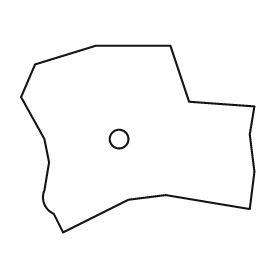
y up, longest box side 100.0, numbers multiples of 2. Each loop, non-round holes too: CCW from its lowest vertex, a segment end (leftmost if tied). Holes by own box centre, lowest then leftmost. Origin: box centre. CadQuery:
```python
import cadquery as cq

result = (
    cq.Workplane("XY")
    .moveTo(-32.0, -40.0)
    .lineTo(-4.0, -26.0)
    .lineTo(12.0, -24.0)
    .lineTo(48.0, -30.0)
    .lineTo(50.0, -14.0)
    .lineTo(48.0, 2.0)
    .lineTo(50.0, 14.0)
    .lineTo(22.0, 16.0)
    .lineTo(14.0, 40.0)
    .lineTo(-18.0, 40.0)
    .lineTo(-44.0, 32.0)
    .lineTo(-50.0, 18.0)
    .lineTo(-40.0, 0.0)
    .lineTo(-38.0, -10.0)
    .lineTo(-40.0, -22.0)
    .threePointArc((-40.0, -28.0), (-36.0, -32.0))
    .close()
    .moveTo(-8.0, 0.0)
    .circle(4.0)
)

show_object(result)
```